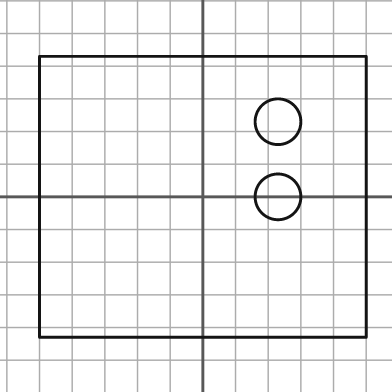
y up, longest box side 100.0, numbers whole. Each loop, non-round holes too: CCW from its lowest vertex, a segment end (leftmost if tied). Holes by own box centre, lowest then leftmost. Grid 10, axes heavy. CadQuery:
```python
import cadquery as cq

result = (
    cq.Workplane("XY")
    .moveTo(-50.0, -43.0)
    .lineTo(50.0, -43.0)
    .lineTo(50.0, 43.0)
    .lineTo(-50.0, 43.0)
    .close()
    .moveTo(23.0, 0.0)
    .circle(7.0)
    .moveTo(23.0, 23.0)
    .circle(7.0)
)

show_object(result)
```